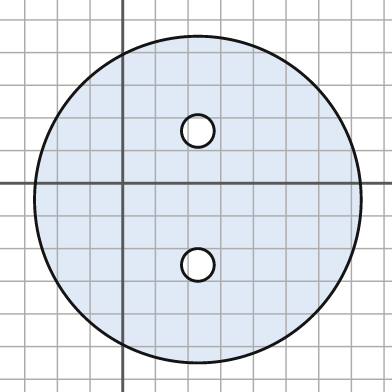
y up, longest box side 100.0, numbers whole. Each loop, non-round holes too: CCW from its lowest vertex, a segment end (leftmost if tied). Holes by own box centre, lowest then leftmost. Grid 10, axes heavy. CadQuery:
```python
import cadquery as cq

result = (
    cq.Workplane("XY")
    .moveTo(23.0, -5.0)
    .circle(50.0)
    .moveTo(23.0, -25.0)
    .circle(5.0)
    .moveTo(23.0, 16.0)
    .circle(5.0)
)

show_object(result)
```